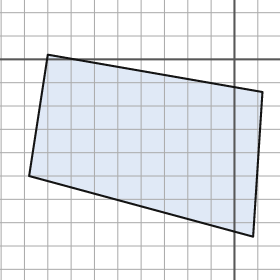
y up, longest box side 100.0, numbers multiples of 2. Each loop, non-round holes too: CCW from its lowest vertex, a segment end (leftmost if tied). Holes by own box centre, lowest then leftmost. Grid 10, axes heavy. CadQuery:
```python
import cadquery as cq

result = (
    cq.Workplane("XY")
    .moveTo(8.0, -76.0)
    .lineTo(12.0, -14.0)
    .lineTo(-80.0, 2.0)
    .lineTo(-88.0, -50.0)
    .close()
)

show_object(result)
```